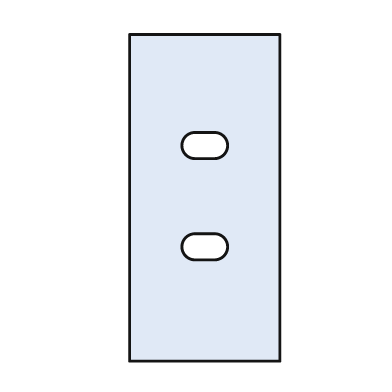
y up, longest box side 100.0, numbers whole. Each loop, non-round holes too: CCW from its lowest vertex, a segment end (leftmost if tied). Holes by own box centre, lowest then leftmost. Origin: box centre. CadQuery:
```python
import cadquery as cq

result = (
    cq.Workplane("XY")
    .moveTo(-23.0, -50.0)
    .lineTo(23.0, -50.0)
    .lineTo(23.0, 50.0)
    .lineTo(-23.0, 50.0)
    .close()
    .moveTo(-3.0, -19.0)
    .lineTo(3.0, -19.0)
    .threePointArc((7.0, -15.0), (3.0, -11.0))
    .lineTo(-3.0, -11.0)
    .threePointArc((-7.0, -15.0), (-3.0, -19.0))
    .close()
    .moveTo(-3.0, 12.0)
    .lineTo(3.0, 12.0)
    .threePointArc((7.0, 16.0), (3.0, 20.0))
    .lineTo(-3.0, 20.0)
    .threePointArc((-7.0, 16.0), (-3.0, 12.0))
    .close()
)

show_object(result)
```